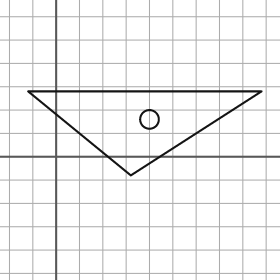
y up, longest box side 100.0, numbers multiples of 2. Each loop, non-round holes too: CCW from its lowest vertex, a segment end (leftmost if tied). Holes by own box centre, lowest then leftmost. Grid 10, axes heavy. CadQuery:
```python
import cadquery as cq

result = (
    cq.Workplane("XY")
    .moveTo(32.0, -8.0)
    .lineTo(88.0, 28.0)
    .lineTo(-12.0, 28.0)
    .close()
    .moveTo(40.0, 16.0)
    .circle(4.0)
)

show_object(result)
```